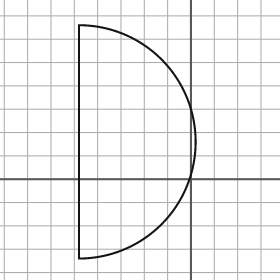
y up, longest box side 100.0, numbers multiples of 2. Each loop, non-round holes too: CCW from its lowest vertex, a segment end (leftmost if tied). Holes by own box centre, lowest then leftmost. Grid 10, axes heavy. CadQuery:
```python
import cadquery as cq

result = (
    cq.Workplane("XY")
    .moveTo(-48.0, -34.0)
    .threePointArc((2.0, 16.0), (-48.0, 66.0))
    .close()
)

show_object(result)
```